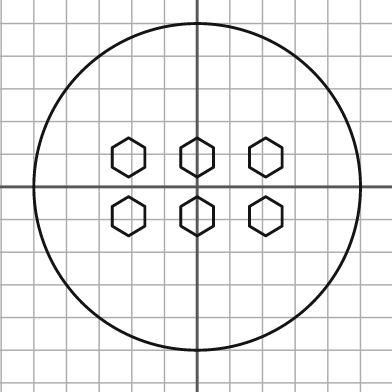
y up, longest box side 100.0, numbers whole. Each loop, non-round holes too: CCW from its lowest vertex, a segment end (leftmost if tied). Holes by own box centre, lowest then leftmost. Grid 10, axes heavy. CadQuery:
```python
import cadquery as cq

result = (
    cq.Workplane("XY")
    .moveTo(0.0, 0.0)
    .circle(50.0)
    .moveTo(-21.0, -15.0)
    .lineTo(-16.0, -12.0)
    .lineTo(-16.0, -6.0)
    .lineTo(-21.0, -3.0)
    .lineTo(-26.0, -6.0)
    .lineTo(-26.0, -12.0)
    .close()
    .moveTo(0.0, -15.0)
    .lineTo(5.0, -12.0)
    .lineTo(5.0, -6.0)
    .lineTo(0.0, -3.0)
    .lineTo(-5.0, -6.0)
    .lineTo(-5.0, -12.0)
    .close()
    .moveTo(21.0, -15.0)
    .lineTo(26.0, -12.0)
    .lineTo(26.0, -6.0)
    .lineTo(21.0, -3.0)
    .lineTo(16.0, -6.0)
    .lineTo(16.0, -12.0)
    .close()
    .moveTo(-21.0, 3.0)
    .lineTo(-16.0, 6.0)
    .lineTo(-16.0, 12.0)
    .lineTo(-21.0, 15.0)
    .lineTo(-26.0, 12.0)
    .lineTo(-26.0, 6.0)
    .close()
    .moveTo(0.0, 3.0)
    .lineTo(5.0, 6.0)
    .lineTo(5.0, 12.0)
    .lineTo(0.0, 15.0)
    .lineTo(-5.0, 12.0)
    .lineTo(-5.0, 6.0)
    .close()
    .moveTo(21.0, 3.0)
    .lineTo(26.0, 6.0)
    .lineTo(26.0, 12.0)
    .lineTo(21.0, 15.0)
    .lineTo(16.0, 12.0)
    .lineTo(16.0, 6.0)
    .close()
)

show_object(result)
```